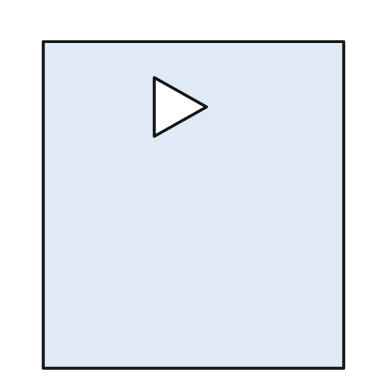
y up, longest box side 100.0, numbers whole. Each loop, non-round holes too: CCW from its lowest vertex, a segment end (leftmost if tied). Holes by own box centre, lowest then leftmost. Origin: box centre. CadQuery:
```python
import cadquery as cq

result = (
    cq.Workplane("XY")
    .moveTo(-46.0, -50.0)
    .lineTo(46.0, -50.0)
    .lineTo(46.0, 50.0)
    .lineTo(-46.0, 50.0)
    .close()
    .moveTo(-12.0, 21.0)
    .lineTo(4.0, 30.0)
    .lineTo(-12.0, 39.0)
    .close()
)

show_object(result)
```